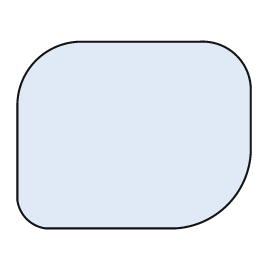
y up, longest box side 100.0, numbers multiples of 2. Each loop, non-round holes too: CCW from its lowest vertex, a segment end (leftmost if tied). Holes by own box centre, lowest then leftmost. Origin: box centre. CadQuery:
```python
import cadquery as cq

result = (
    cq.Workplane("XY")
    .moveTo(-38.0, -40.0)
    .lineTo(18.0, -40.0)
    .threePointArc((40.0, -30.0), (50.0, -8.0))
    .lineTo(50.0, 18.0)
    .threePointArc((44.0, 34.0), (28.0, 40.0))
    .lineTo(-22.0, 40.0)
    .threePointArc((-42.0, 32.0), (-50.0, 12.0))
    .lineTo(-50.0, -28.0)
    .threePointArc((-46.0, -36.0), (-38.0, -40.0))
    .close()
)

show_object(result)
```